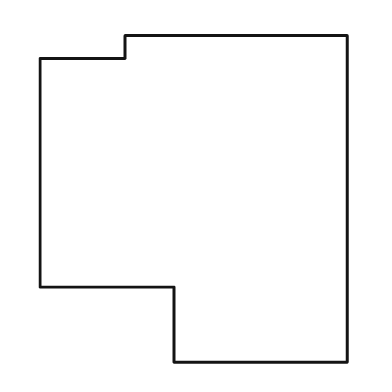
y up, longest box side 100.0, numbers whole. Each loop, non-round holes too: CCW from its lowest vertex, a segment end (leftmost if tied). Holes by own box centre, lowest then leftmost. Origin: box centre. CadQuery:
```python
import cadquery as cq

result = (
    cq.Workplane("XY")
    .moveTo(-6.0, -50.0)
    .lineTo(47.0, -50.0)
    .lineTo(47.0, 50.0)
    .lineTo(-21.0, 50.0)
    .lineTo(-21.0, 43.0)
    .lineTo(-47.0, 43.0)
    .lineTo(-47.0, -27.0)
    .lineTo(-6.0, -27.0)
    .close()
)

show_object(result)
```